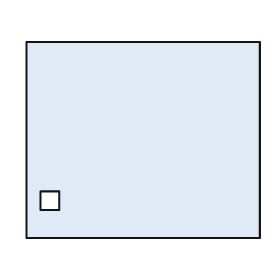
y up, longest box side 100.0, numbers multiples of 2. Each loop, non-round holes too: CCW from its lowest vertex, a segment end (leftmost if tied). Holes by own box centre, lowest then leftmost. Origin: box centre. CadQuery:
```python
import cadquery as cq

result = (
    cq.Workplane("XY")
    .moveTo(-50.0, -42.0)
    .lineTo(50.0, -42.0)
    .lineTo(50.0, 42.0)
    .lineTo(-50.0, 42.0)
    .close()
    .moveTo(-44.0, -30.0)
    .lineTo(-36.0, -30.0)
    .lineTo(-36.0, -22.0)
    .lineTo(-44.0, -22.0)
    .close()
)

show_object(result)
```